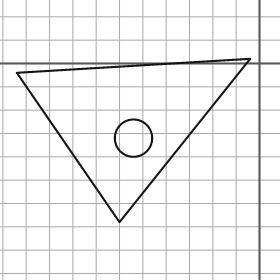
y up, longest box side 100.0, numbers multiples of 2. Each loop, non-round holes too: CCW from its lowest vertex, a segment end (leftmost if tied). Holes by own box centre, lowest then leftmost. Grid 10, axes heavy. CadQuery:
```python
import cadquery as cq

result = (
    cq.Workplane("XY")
    .moveTo(-60.0, -68.0)
    .lineTo(-4.0, 2.0)
    .lineTo(-104.0, -4.0)
    .close()
    .moveTo(-54.0, -32.0)
    .circle(8.0)
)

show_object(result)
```